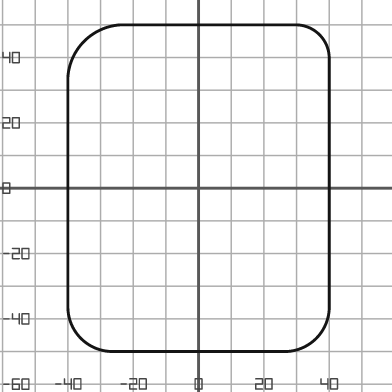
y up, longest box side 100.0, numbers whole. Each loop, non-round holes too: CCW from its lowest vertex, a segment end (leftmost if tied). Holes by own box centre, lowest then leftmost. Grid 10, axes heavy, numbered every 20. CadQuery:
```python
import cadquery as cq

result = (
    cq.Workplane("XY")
    .moveTo(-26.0, -50.0)
    .lineTo(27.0, -50.0)
    .threePointArc((36.0, -46.0), (40.0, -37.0))
    .lineTo(40.0, 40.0)
    .threePointArc((37.0, 47.0), (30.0, 50.0))
    .lineTo(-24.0, 50.0)
    .threePointArc((-35.0, 45.0), (-40.0, 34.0))
    .lineTo(-40.0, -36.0)
    .threePointArc((-36.0, -46.0), (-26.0, -50.0))
    .close()
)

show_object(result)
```